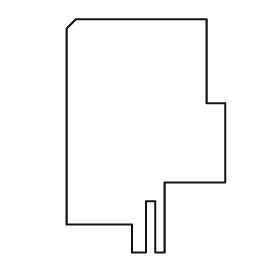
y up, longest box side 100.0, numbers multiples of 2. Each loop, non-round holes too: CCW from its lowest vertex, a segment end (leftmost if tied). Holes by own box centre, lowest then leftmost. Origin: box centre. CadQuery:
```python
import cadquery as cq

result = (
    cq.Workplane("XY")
    .moveTo(-6.0, -50.0)
    .lineTo(0.0, -50.0)
    .lineTo(0.0, -28.0)
    .lineTo(4.0, -28.0)
    .lineTo(4.0, -50.0)
    .lineTo(8.0, -50.0)
    .lineTo(8.0, -20.0)
    .lineTo(34.0, -20.0)
    .lineTo(34.0, 14.0)
    .lineTo(26.0, 14.0)
    .lineTo(26.0, 50.0)
    .lineTo(-30.0, 50.0)
    .lineTo(-34.0, 46.0)
    .lineTo(-34.0, -38.0)
    .lineTo(-6.0, -38.0)
    .close()
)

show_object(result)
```